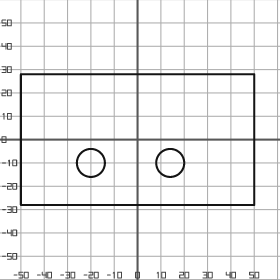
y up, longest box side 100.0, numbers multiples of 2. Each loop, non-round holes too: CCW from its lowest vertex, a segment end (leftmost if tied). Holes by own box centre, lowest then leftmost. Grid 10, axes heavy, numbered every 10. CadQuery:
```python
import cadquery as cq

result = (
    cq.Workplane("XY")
    .moveTo(-50.0, -28.0)
    .lineTo(50.0, -28.0)
    .lineTo(50.0, 28.0)
    .lineTo(-50.0, 28.0)
    .close()
    .moveTo(-20.0, -10.0)
    .circle(6.0)
    .moveTo(14.0, -10.0)
    .circle(6.0)
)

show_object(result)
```